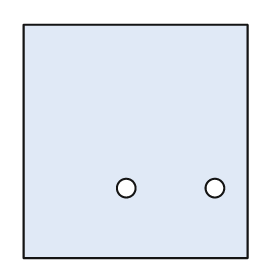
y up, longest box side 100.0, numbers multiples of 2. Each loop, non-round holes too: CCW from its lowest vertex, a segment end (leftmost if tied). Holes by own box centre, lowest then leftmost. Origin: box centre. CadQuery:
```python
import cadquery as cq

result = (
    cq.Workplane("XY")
    .moveTo(-48.0, -50.0)
    .lineTo(48.0, -50.0)
    .lineTo(48.0, 50.0)
    .lineTo(-48.0, 50.0)
    .close()
    .moveTo(-4.0, -20.0)
    .circle(4.0)
    .moveTo(34.0, -20.0)
    .circle(4.0)
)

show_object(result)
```